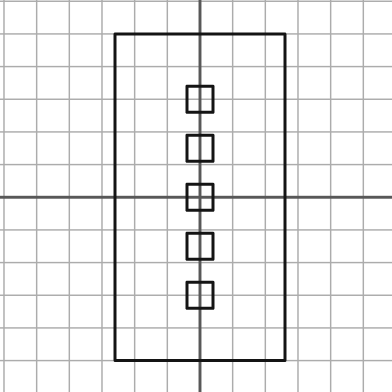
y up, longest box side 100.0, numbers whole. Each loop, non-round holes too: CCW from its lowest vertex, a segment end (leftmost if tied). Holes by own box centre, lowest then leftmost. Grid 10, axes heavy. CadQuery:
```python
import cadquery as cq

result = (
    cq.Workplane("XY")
    .moveTo(-26.0, -50.0)
    .lineTo(26.0, -50.0)
    .lineTo(26.0, 50.0)
    .lineTo(-26.0, 50.0)
    .close()
    .moveTo(-4.0, -34.0)
    .lineTo(4.0, -34.0)
    .lineTo(4.0, -26.0)
    .lineTo(-4.0, -26.0)
    .close()
    .moveTo(-4.0, -19.0)
    .lineTo(4.0, -19.0)
    .lineTo(4.0, -11.0)
    .lineTo(-4.0, -11.0)
    .close()
    .moveTo(-4.0, -4.0)
    .lineTo(4.0, -4.0)
    .lineTo(4.0, 4.0)
    .lineTo(-4.0, 4.0)
    .close()
    .moveTo(-4.0, 11.0)
    .lineTo(4.0, 11.0)
    .lineTo(4.0, 19.0)
    .lineTo(-4.0, 19.0)
    .close()
    .moveTo(-4.0, 26.0)
    .lineTo(4.0, 26.0)
    .lineTo(4.0, 34.0)
    .lineTo(-4.0, 34.0)
    .close()
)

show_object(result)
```